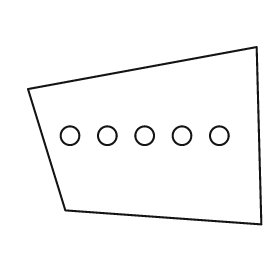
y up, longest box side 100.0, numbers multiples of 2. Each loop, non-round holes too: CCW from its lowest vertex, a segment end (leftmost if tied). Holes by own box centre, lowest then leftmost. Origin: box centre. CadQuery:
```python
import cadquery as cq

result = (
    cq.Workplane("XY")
    .moveTo(50.0, -38.0)
    .lineTo(48.0, 38.0)
    .lineTo(-50.0, 20.0)
    .lineTo(-34.0, -32.0)
    .close()
    .moveTo(-32.0, 0.0)
    .circle(4.0)
    .moveTo(-16.0, 0.0)
    .circle(4.0)
    .moveTo(0.0, 0.0)
    .circle(4.0)
    .moveTo(16.0, 0.0)
    .circle(4.0)
    .moveTo(32.0, 0.0)
    .circle(4.0)
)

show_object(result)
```